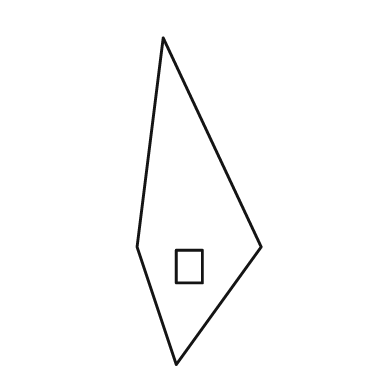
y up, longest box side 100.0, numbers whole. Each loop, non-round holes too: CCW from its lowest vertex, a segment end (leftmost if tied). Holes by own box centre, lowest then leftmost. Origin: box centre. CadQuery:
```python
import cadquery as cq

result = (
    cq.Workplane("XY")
    .moveTo(-7.0, -50.0)
    .lineTo(19.0, -14.0)
    .lineTo(-11.0, 50.0)
    .lineTo(-19.0, -14.0)
    .close()
    .moveTo(-7.0, -25.0)
    .lineTo(1.0, -25.0)
    .lineTo(1.0, -15.0)
    .lineTo(-7.0, -15.0)
    .close()
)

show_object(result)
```